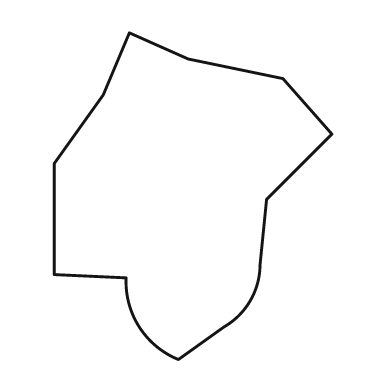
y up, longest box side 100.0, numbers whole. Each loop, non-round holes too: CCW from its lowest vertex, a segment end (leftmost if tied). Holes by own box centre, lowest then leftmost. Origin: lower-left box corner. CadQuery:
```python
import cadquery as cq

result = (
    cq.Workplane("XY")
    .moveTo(38.0, 0.0)
    .lineTo(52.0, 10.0)
    .threePointArc((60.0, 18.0), (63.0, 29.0))
    .lineTo(65.0, 49.0)
    .lineTo(85.0, 69.0)
    .lineTo(70.0, 86.0)
    .lineTo(41.0, 92.0)
    .lineTo(23.0, 100.0)
    .lineTo(15.0, 81.0)
    .lineTo(0.0, 60.0)
    .lineTo(0.0, 26.0)
    .lineTo(22.0, 25.0)
    .threePointArc((26.0, 10.0), (38.0, 0.0))
    .close()
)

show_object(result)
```